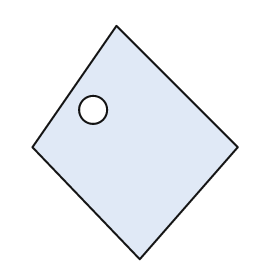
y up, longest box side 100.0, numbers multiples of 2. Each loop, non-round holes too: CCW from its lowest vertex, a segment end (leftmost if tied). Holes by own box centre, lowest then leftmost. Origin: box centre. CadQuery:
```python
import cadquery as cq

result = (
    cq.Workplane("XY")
    .moveTo(2.0, -50.0)
    .lineTo(44.0, -2.0)
    .lineTo(-8.0, 50.0)
    .lineTo(-44.0, -2.0)
    .close()
    .moveTo(-18.0, 14.0)
    .circle(6.0)
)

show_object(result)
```